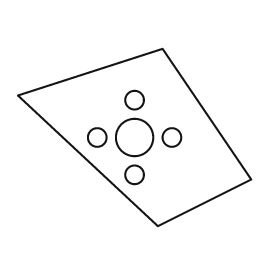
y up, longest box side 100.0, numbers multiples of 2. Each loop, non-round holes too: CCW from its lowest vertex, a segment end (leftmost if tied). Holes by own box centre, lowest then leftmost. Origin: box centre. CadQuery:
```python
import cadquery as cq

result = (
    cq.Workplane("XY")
    .moveTo(10.0, -38.0)
    .lineTo(50.0, -18.0)
    .lineTo(12.0, 38.0)
    .lineTo(-50.0, 18.0)
    .close()
    .moveTo(0.0, -16.0)
    .circle(4.0)
    .moveTo(-16.0, 0.0)
    .circle(4.0)
    .moveTo(0.0, 0.0)
    .circle(8.0)
    .moveTo(16.0, 0.0)
    .circle(4.0)
    .moveTo(0.0, 16.0)
    .circle(4.0)
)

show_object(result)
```